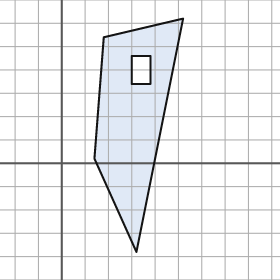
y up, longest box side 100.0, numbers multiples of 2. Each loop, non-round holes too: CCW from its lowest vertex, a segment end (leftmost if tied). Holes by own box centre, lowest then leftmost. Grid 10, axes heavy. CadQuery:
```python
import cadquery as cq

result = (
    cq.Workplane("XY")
    .moveTo(32.0, -38.0)
    .lineTo(52.0, 62.0)
    .lineTo(18.0, 54.0)
    .lineTo(14.0, 2.0)
    .close()
    .moveTo(30.0, 34.0)
    .lineTo(38.0, 34.0)
    .lineTo(38.0, 46.0)
    .lineTo(30.0, 46.0)
    .close()
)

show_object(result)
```